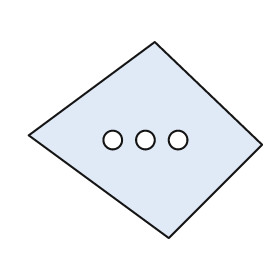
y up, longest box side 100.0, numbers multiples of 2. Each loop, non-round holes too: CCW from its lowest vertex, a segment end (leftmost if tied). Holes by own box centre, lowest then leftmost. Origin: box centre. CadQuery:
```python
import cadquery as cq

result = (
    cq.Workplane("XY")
    .moveTo(10.0, -42.0)
    .lineTo(50.0, -2.0)
    .lineTo(4.0, 42.0)
    .lineTo(-50.0, 2.0)
    .close()
    .moveTo(-14.0, 0.0)
    .circle(4.0)
    .moveTo(0.0, 0.0)
    .circle(4.0)
    .moveTo(14.0, 0.0)
    .circle(4.0)
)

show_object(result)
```